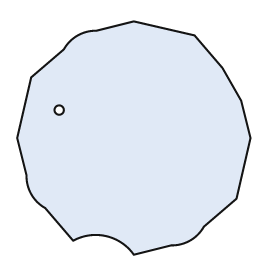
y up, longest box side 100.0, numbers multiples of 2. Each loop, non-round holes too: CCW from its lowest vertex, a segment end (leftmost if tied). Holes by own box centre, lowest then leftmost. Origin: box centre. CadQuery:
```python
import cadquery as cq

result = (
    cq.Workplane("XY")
    .moveTo(0.0, -50.0)
    .lineTo(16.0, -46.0)
    .threePointArc((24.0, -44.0), (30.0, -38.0))
    .lineTo(44.0, -26.0)
    .lineTo(50.0, 0.0)
    .lineTo(46.0, 16.0)
    .lineTo(38.0, 30.0)
    .lineTo(26.0, 44.0)
    .lineTo(0.0, 50.0)
    .lineTo(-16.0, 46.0)
    .threePointArc((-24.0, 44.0), (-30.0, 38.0))
    .lineTo(-44.0, 26.0)
    .lineTo(-50.0, 0.0)
    .lineTo(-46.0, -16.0)
    .threePointArc((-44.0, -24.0), (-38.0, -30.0))
    .lineTo(-26.0, -44.0)
    .threePointArc((-12.0, -42.0), (0.0, -50.0))
    .close()
    .moveTo(-32.0, 12.0)
    .circle(2.0)
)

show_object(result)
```